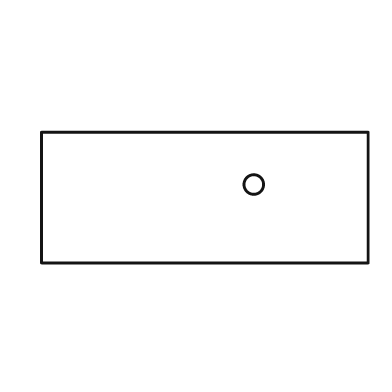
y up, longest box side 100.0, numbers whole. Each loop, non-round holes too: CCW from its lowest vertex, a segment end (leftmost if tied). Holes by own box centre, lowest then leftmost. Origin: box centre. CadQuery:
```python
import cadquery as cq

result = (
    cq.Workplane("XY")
    .moveTo(-50.0, -20.0)
    .lineTo(50.0, -20.0)
    .lineTo(50.0, 20.0)
    .lineTo(-50.0, 20.0)
    .close()
    .moveTo(15.0, 4.0)
    .circle(3.0)
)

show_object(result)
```